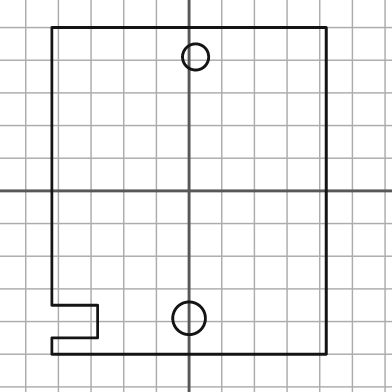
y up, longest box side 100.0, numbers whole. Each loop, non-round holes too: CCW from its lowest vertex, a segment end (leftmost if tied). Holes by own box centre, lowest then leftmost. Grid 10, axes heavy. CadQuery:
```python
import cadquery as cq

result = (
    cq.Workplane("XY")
    .moveTo(-42.0, -50.0)
    .lineTo(42.0, -50.0)
    .lineTo(42.0, 50.0)
    .lineTo(-42.0, 50.0)
    .lineTo(-42.0, -35.0)
    .lineTo(-28.0, -35.0)
    .lineTo(-28.0, -45.0)
    .lineTo(-42.0, -45.0)
    .close()
    .moveTo(0.0, -39.0)
    .circle(5.0)
    .moveTo(2.0, 41.0)
    .circle(4.0)
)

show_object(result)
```